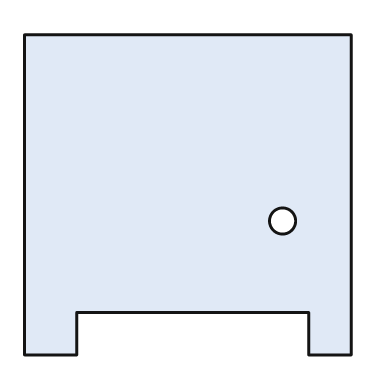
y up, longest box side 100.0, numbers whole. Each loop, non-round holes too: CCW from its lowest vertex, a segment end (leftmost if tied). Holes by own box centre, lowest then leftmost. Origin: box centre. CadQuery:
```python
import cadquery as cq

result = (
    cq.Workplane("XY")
    .moveTo(-50.0, -49.0)
    .lineTo(-34.0, -49.0)
    .lineTo(-34.0, -36.0)
    .lineTo(37.0, -36.0)
    .lineTo(37.0, -49.0)
    .lineTo(50.0, -49.0)
    .lineTo(50.0, 49.0)
    .lineTo(-50.0, 49.0)
    .close()
    .moveTo(29.0, -8.0)
    .circle(4.0)
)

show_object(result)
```